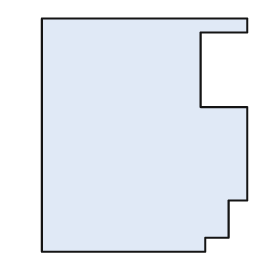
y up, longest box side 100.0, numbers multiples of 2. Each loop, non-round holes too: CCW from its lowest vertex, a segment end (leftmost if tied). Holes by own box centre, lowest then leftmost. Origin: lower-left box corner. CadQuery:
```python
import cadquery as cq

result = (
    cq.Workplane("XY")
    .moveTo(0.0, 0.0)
    .lineTo(70.0, 0.0)
    .lineTo(70.0, 6.0)
    .lineTo(80.0, 6.0)
    .lineTo(80.0, 22.0)
    .lineTo(88.0, 22.0)
    .lineTo(88.0, 62.0)
    .lineTo(68.0, 62.0)
    .lineTo(68.0, 94.0)
    .lineTo(88.0, 94.0)
    .lineTo(88.0, 100.0)
    .lineTo(0.0, 100.0)
    .close()
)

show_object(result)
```